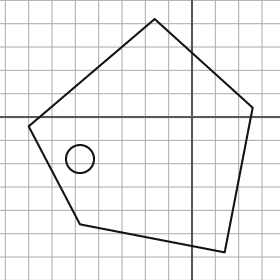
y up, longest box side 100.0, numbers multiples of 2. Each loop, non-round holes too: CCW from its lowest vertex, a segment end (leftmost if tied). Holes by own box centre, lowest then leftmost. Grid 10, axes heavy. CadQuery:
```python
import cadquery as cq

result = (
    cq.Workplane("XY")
    .moveTo(14.0, -58.0)
    .lineTo(26.0, 4.0)
    .lineTo(-16.0, 42.0)
    .lineTo(-70.0, -4.0)
    .lineTo(-48.0, -46.0)
    .close()
    .moveTo(-48.0, -18.0)
    .circle(6.0)
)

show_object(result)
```